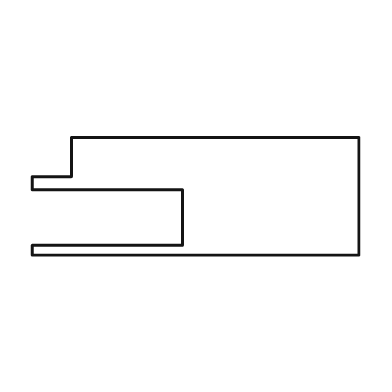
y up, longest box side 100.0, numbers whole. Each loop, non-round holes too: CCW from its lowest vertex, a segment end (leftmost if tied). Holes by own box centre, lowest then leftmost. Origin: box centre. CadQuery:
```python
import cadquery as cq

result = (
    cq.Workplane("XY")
    .moveTo(-50.0, -18.0)
    .lineTo(50.0, -18.0)
    .lineTo(50.0, 18.0)
    .lineTo(-38.0, 18.0)
    .lineTo(-38.0, 6.0)
    .lineTo(-50.0, 6.0)
    .lineTo(-50.0, 2.0)
    .lineTo(-4.0, 2.0)
    .lineTo(-4.0, -15.0)
    .lineTo(-50.0, -15.0)
    .close()
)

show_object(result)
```